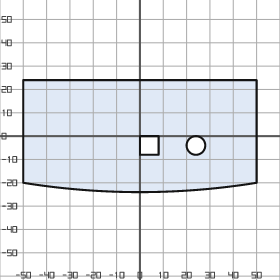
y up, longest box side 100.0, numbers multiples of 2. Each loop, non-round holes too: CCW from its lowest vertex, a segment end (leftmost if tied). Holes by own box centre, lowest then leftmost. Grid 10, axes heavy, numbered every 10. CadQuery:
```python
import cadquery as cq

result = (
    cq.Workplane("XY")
    .moveTo(-50.0, -20.0)
    .threePointArc((0.0, -24.0), (50.0, -20.0))
    .lineTo(50.0, 24.0)
    .lineTo(-50.0, 24.0)
    .close()
    .moveTo(0.0, -8.0)
    .lineTo(8.0, -8.0)
    .lineTo(8.0, 0.0)
    .lineTo(0.0, 0.0)
    .close()
    .moveTo(24.0, -4.0)
    .circle(4.0)
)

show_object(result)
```